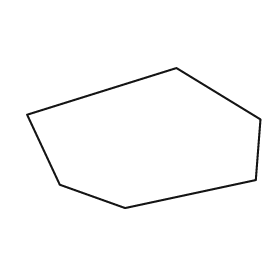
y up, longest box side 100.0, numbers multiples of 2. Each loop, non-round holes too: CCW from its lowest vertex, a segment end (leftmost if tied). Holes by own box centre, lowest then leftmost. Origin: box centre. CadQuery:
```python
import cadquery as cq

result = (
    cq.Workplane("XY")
    .moveTo(-8.0, -30.0)
    .lineTo(48.0, -18.0)
    .lineTo(50.0, 8.0)
    .lineTo(14.0, 30.0)
    .lineTo(-50.0, 10.0)
    .lineTo(-36.0, -20.0)
    .close()
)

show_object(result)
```